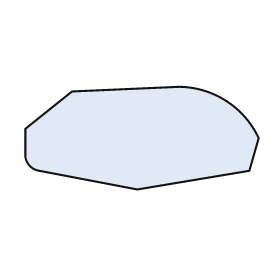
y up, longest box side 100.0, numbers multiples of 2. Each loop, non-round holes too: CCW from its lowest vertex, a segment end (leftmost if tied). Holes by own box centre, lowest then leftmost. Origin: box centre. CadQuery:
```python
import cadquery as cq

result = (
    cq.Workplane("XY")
    .moveTo(-2.0, -22.0)
    .lineTo(46.0, -14.0)
    .lineTo(50.0, 0.0)
    .threePointArc((36.0, 16.0), (16.0, 22.0))
    .lineTo(-30.0, 20.0)
    .lineTo(-50.0, 4.0)
    .lineTo(-50.0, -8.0)
    .threePointArc((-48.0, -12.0), (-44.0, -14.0))
    .close()
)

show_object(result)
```